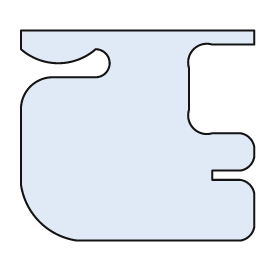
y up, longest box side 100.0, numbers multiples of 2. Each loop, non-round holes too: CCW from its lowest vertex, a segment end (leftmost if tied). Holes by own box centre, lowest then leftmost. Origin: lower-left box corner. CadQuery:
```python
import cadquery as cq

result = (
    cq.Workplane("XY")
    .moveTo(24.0, 0.0)
    .lineTo(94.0, 0.0)
    .threePointArc((98.0, 2.0), (100.0, 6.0))
    .lineTo(100.0, 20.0)
    .threePointArc((98.0, 24.0), (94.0, 26.0))
    .lineTo(82.0, 26.0)
    .lineTo(82.0, 30.0)
    .lineTo(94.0, 30.0)
    .threePointArc((98.0, 32.0), (100.0, 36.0))
    .lineTo(100.0, 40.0)
    .threePointArc((98.0, 44.0), (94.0, 46.0))
    .lineTo(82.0, 46.0)
    .threePointArc((74.0, 48.0), (72.0, 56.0))
    .lineTo(72.0, 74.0)
    .threePointArc((74.0, 82.0), (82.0, 84.0))
    .lineTo(100.0, 84.0)
    .lineTo(100.0, 90.0)
    .lineTo(0.0, 90.0)
    .lineTo(0.0, 82.0)
    .threePointArc((16.0, 76.0), (32.0, 82.0))
    .threePointArc((38.0, 76.0), (32.0, 70.0))
    .lineTo(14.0, 70.0)
    .threePointArc((4.0, 66.0), (0.0, 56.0))
    .lineTo(0.0, 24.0)
    .threePointArc((8.0, 8.0), (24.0, 0.0))
    .close()
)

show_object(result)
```